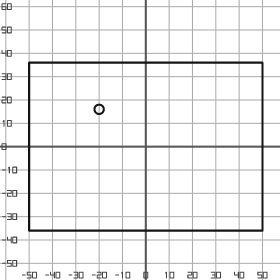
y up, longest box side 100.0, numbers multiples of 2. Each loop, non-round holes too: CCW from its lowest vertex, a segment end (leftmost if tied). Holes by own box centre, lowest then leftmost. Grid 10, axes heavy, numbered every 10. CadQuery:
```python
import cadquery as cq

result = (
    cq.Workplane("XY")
    .moveTo(-50.0, -36.0)
    .lineTo(50.0, -36.0)
    .lineTo(50.0, 36.0)
    .lineTo(-50.0, 36.0)
    .close()
    .moveTo(-20.0, 16.0)
    .circle(2.0)
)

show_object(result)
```